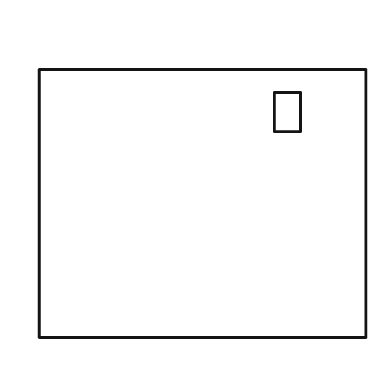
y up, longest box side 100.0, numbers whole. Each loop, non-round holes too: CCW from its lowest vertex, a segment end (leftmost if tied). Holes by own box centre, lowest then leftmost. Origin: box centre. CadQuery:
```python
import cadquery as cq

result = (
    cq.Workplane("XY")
    .moveTo(-50.0, -41.0)
    .lineTo(50.0, -41.0)
    .lineTo(50.0, 41.0)
    .lineTo(-50.0, 41.0)
    .close()
    .moveTo(22.0, 22.0)
    .lineTo(30.0, 22.0)
    .lineTo(30.0, 34.0)
    .lineTo(22.0, 34.0)
    .close()
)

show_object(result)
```